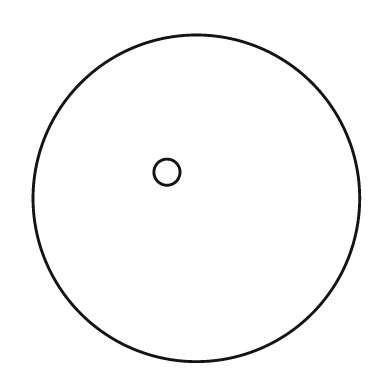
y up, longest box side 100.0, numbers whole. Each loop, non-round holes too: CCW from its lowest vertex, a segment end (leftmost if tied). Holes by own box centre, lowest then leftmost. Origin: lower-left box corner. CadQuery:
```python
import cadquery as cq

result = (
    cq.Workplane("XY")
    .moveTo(50.0, 50.0)
    .circle(50.0)
    .moveTo(41.0, 58.0)
    .circle(4.0)
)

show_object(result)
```